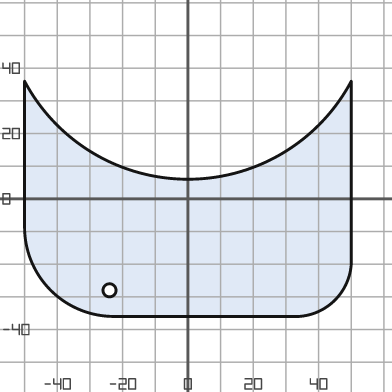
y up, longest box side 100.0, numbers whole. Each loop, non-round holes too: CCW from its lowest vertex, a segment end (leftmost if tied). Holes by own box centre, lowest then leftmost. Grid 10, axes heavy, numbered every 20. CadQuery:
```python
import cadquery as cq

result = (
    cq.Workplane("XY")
    .moveTo(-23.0, -36.0)
    .lineTo(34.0, -36.0)
    .threePointArc((45.0, -31.0), (50.0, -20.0))
    .lineTo(50.0, 36.0)
    .threePointArc((0.0, 6.0), (-50.0, 36.0))
    .lineTo(-50.0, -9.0)
    .threePointArc((-42.0, -28.0), (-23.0, -36.0))
    .close()
    .moveTo(-24.0, -28.0)
    .circle(2.0)
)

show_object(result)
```